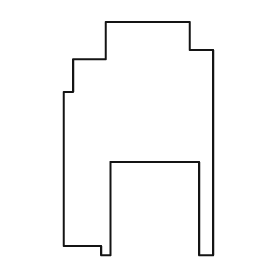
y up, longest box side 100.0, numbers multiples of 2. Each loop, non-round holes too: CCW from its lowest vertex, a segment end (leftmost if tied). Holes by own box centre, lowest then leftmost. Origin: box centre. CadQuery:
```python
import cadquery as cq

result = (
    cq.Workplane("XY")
    .moveTo(-16.0, -50.0)
    .lineTo(-12.0, -50.0)
    .lineTo(-12.0, -10.0)
    .lineTo(26.0, -10.0)
    .lineTo(26.0, -50.0)
    .lineTo(32.0, -50.0)
    .lineTo(32.0, 38.0)
    .lineTo(22.0, 38.0)
    .lineTo(22.0, 50.0)
    .lineTo(-14.0, 50.0)
    .lineTo(-14.0, 34.0)
    .lineTo(-28.0, 34.0)
    .lineTo(-28.0, 20.0)
    .lineTo(-32.0, 20.0)
    .lineTo(-32.0, -46.0)
    .lineTo(-16.0, -46.0)
    .close()
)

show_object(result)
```